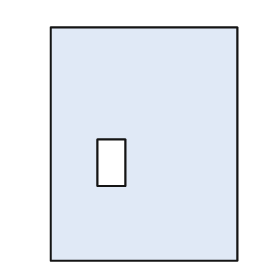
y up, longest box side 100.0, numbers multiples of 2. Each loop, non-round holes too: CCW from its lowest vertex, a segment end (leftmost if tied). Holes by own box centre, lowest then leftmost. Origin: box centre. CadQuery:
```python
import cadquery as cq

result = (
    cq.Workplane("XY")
    .moveTo(-40.0, -50.0)
    .lineTo(40.0, -50.0)
    .lineTo(40.0, 50.0)
    .lineTo(-40.0, 50.0)
    .close()
    .moveTo(-20.0, -18.0)
    .lineTo(-8.0, -18.0)
    .lineTo(-8.0, 2.0)
    .lineTo(-20.0, 2.0)
    .close()
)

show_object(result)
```